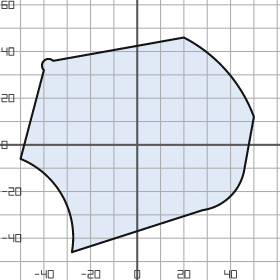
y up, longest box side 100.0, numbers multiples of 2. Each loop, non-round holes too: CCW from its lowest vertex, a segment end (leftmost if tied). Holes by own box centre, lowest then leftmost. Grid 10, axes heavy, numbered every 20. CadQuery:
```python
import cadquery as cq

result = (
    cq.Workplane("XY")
    .moveTo(-28.0, -46.0)
    .lineTo(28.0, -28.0)
    .threePointArc((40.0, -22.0), (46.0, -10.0))
    .lineTo(50.0, 12.0)
    .threePointArc((38.0, 32.0), (20.0, 46.0))
    .lineTo(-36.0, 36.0)
    .threePointArc((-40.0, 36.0), (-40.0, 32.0))
    .lineTo(-50.0, -6.0)
    .threePointArc((-32.0, -22.0), (-28.0, -46.0))
    .close()
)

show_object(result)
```